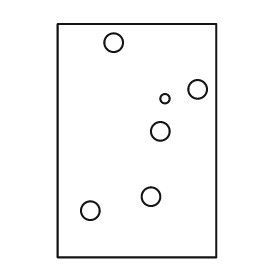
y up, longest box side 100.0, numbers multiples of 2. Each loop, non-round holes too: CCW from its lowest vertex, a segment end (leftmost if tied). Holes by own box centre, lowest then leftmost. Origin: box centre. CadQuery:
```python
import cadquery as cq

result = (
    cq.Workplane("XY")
    .moveTo(-34.0, -50.0)
    .lineTo(34.0, -50.0)
    .lineTo(34.0, 50.0)
    .lineTo(-34.0, 50.0)
    .close()
    .moveTo(-20.0, -30.0)
    .circle(4.0)
    .moveTo(6.0, -24.0)
    .circle(4.0)
    .moveTo(10.0, 4.0)
    .circle(4.0)
    .moveTo(12.0, 18.0)
    .circle(2.0)
    .moveTo(26.0, 22.0)
    .circle(4.0)
    .moveTo(-10.0, 42.0)
    .circle(4.0)
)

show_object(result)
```